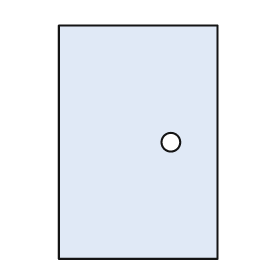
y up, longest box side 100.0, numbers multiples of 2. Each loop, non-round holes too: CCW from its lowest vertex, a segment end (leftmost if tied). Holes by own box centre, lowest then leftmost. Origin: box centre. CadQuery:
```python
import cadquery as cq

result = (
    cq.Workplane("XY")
    .moveTo(-34.0, -50.0)
    .lineTo(34.0, -50.0)
    .lineTo(34.0, 50.0)
    .lineTo(-34.0, 50.0)
    .close()
    .moveTo(14.0, 0.0)
    .circle(4.0)
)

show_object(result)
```